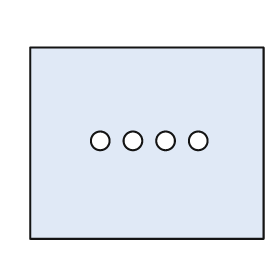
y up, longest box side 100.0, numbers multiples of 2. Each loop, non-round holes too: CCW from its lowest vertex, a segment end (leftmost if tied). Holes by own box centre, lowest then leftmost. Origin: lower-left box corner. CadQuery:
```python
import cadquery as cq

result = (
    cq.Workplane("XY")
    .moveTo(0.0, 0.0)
    .lineTo(100.0, 0.0)
    .lineTo(100.0, 82.0)
    .lineTo(0.0, 82.0)
    .close()
    .moveTo(30.0, 42.0)
    .circle(4.0)
    .moveTo(44.0, 42.0)
    .circle(4.0)
    .moveTo(58.0, 42.0)
    .circle(4.0)
    .moveTo(72.0, 42.0)
    .circle(4.0)
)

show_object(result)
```